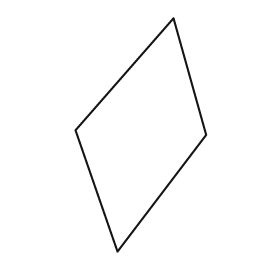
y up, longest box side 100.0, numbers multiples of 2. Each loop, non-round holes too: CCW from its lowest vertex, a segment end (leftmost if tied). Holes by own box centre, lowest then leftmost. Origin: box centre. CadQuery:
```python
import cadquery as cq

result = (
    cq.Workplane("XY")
    .moveTo(-10.0, -50.0)
    .lineTo(28.0, 0.0)
    .lineTo(14.0, 50.0)
    .lineTo(-28.0, 2.0)
    .close()
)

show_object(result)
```